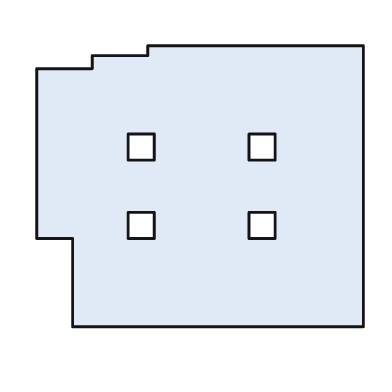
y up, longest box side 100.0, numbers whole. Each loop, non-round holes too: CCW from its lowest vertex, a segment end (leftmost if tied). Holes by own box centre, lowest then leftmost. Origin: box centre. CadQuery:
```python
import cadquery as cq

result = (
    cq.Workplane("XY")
    .moveTo(-39.0, -43.0)
    .lineTo(50.0, -43.0)
    .lineTo(50.0, 43.0)
    .lineTo(-16.0, 43.0)
    .lineTo(-16.0, 40.0)
    .lineTo(-33.0, 40.0)
    .lineTo(-33.0, 36.0)
    .lineTo(-50.0, 36.0)
    .lineTo(-50.0, -16.0)
    .lineTo(-39.0, -16.0)
    .close()
    .moveTo(-22.0, -16.0)
    .lineTo(-14.0, -16.0)
    .lineTo(-14.0, -8.0)
    .lineTo(-22.0, -8.0)
    .close()
    .moveTo(15.0, -16.0)
    .lineTo(23.0, -16.0)
    .lineTo(23.0, -8.0)
    .lineTo(15.0, -8.0)
    .close()
    .moveTo(-22.0, 8.0)
    .lineTo(-14.0, 8.0)
    .lineTo(-14.0, 16.0)
    .lineTo(-22.0, 16.0)
    .close()
    .moveTo(15.0, 8.0)
    .lineTo(23.0, 8.0)
    .lineTo(23.0, 16.0)
    .lineTo(15.0, 16.0)
    .close()
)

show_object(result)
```